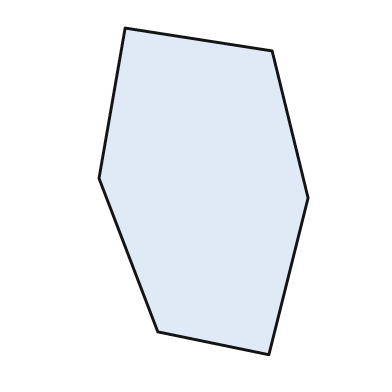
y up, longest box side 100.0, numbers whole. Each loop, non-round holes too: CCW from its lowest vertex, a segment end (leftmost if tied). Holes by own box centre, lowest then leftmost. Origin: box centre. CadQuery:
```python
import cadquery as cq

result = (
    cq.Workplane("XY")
    .moveTo(20.0, -50.0)
    .lineTo(32.0, -2.0)
    .lineTo(21.0, 43.0)
    .lineTo(-24.0, 50.0)
    .lineTo(-32.0, 4.0)
    .lineTo(-14.0, -43.0)
    .close()
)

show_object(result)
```